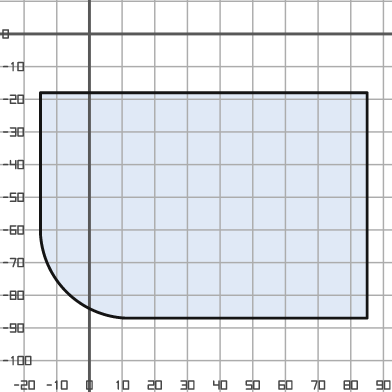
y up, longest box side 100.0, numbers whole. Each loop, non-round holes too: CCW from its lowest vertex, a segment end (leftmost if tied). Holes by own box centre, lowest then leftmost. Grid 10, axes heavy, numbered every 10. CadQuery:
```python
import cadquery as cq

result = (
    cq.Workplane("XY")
    .moveTo(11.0, -87.0)
    .lineTo(85.0, -87.0)
    .lineTo(85.0, -18.0)
    .lineTo(-15.0, -18.0)
    .lineTo(-15.0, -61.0)
    .threePointArc((-7.0, -79.0), (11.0, -87.0))
    .close()
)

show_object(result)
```